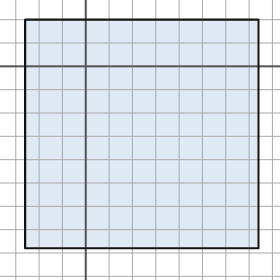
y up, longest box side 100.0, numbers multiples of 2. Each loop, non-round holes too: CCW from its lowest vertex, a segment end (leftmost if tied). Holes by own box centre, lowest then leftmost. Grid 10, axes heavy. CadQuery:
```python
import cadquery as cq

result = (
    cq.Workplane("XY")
    .moveTo(-26.0, -78.0)
    .lineTo(74.0, -78.0)
    .lineTo(74.0, 20.0)
    .lineTo(-26.0, 20.0)
    .close()
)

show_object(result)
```